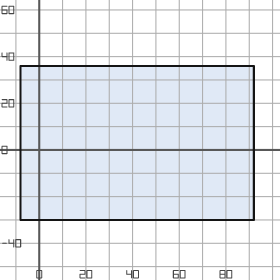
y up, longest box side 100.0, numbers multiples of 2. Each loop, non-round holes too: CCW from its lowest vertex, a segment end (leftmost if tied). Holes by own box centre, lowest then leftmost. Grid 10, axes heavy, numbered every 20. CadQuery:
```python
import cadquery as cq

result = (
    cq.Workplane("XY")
    .moveTo(-8.0, -30.0)
    .lineTo(92.0, -30.0)
    .lineTo(92.0, 36.0)
    .lineTo(-8.0, 36.0)
    .close()
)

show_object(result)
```